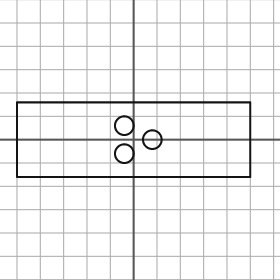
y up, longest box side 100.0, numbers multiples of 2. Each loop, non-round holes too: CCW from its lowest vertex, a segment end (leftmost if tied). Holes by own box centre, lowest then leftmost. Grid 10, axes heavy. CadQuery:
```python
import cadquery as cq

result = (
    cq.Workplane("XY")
    .moveTo(-50.0, -16.0)
    .lineTo(50.0, -16.0)
    .lineTo(50.0, 16.0)
    .lineTo(-50.0, 16.0)
    .close()
    .moveTo(-4.0, -6.0)
    .circle(4.0)
    .moveTo(8.0, 0.0)
    .circle(4.0)
    .moveTo(-4.0, 6.0)
    .circle(4.0)
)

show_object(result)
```